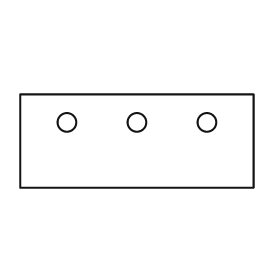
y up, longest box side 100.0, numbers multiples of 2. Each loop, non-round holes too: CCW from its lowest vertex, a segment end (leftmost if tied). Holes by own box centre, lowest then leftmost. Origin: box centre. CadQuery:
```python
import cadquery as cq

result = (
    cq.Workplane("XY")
    .moveTo(-50.0, -20.0)
    .lineTo(50.0, -20.0)
    .lineTo(50.0, 20.0)
    .lineTo(-50.0, 20.0)
    .close()
    .moveTo(-30.0, 8.0)
    .circle(4.0)
    .moveTo(0.0, 8.0)
    .circle(4.0)
    .moveTo(30.0, 8.0)
    .circle(4.0)
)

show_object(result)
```